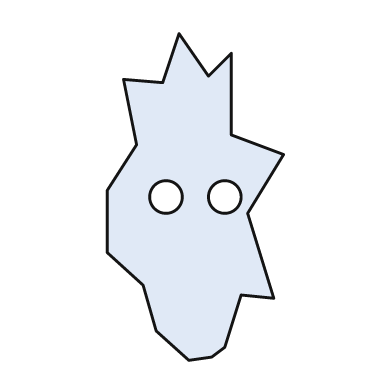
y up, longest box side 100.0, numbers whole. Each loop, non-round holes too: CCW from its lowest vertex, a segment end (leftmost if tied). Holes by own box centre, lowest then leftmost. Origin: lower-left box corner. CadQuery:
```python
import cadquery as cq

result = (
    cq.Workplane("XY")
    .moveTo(25.0, 0.0)
    .lineTo(32.0, 1.0)
    .lineTo(36.0, 4.0)
    .lineTo(41.0, 20.0)
    .lineTo(51.0, 19.0)
    .lineTo(43.0, 45.0)
    .lineTo(54.0, 63.0)
    .lineTo(38.0, 69.0)
    .lineTo(38.0, 94.0)
    .lineTo(31.0, 87.0)
    .lineTo(22.0, 100.0)
    .lineTo(17.0, 85.0)
    .lineTo(5.0, 86.0)
    .lineTo(9.0, 66.0)
    .lineTo(0.0, 52.0)
    .lineTo(0.0, 33.0)
    .lineTo(11.0, 23.0)
    .lineTo(15.0, 9.0)
    .close()
    .moveTo(18.0, 50.0)
    .circle(5.0)
    .moveTo(36.0, 50.0)
    .circle(5.0)
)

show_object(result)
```